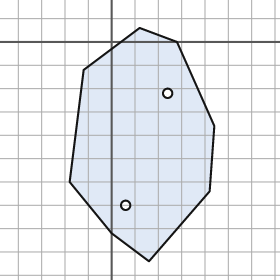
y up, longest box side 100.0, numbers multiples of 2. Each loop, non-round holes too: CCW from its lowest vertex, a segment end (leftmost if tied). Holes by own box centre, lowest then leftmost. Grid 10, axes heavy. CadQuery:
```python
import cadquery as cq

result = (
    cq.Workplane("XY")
    .moveTo(16.0, -94.0)
    .lineTo(42.0, -64.0)
    .lineTo(44.0, -36.0)
    .lineTo(28.0, 0.0)
    .lineTo(12.0, 6.0)
    .lineTo(-12.0, -12.0)
    .lineTo(-18.0, -60.0)
    .lineTo(0.0, -82.0)
    .close()
    .moveTo(6.0, -70.0)
    .circle(2.0)
    .moveTo(24.0, -22.0)
    .circle(2.0)
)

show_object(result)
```